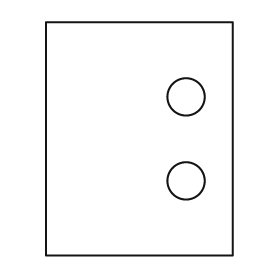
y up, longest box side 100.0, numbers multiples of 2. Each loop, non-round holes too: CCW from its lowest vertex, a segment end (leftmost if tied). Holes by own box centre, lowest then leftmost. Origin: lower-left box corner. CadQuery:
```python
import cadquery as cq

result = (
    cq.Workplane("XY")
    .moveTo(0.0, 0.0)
    .lineTo(80.0, 0.0)
    .lineTo(80.0, 100.0)
    .lineTo(0.0, 100.0)
    .close()
    .moveTo(60.0, 32.0)
    .circle(8.0)
    .moveTo(60.0, 68.0)
    .circle(8.0)
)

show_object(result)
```